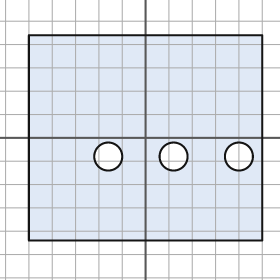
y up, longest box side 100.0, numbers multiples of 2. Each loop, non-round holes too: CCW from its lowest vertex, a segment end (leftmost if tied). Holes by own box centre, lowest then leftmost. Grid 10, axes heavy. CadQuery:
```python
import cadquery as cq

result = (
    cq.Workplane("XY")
    .moveTo(-50.0, -44.0)
    .lineTo(50.0, -44.0)
    .lineTo(50.0, 44.0)
    .lineTo(-50.0, 44.0)
    .close()
    .moveTo(-16.0, -8.0)
    .circle(6.0)
    .moveTo(12.0, -8.0)
    .circle(6.0)
    .moveTo(40.0, -8.0)
    .circle(6.0)
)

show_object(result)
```